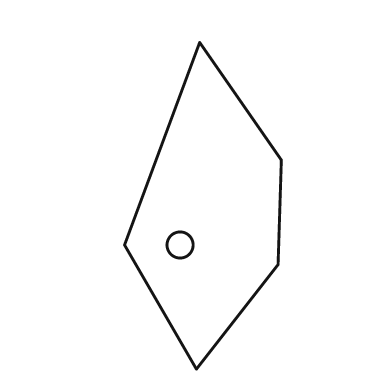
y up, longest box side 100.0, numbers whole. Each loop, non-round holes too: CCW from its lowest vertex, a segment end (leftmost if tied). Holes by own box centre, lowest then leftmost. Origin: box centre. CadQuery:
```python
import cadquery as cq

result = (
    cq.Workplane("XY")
    .moveTo(-2.0, -50.0)
    .lineTo(23.0, -18.0)
    .lineTo(24.0, 14.0)
    .lineTo(-1.0, 50.0)
    .lineTo(-24.0, -12.0)
    .close()
    .moveTo(-7.0, -12.0)
    .circle(4.0)
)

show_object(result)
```